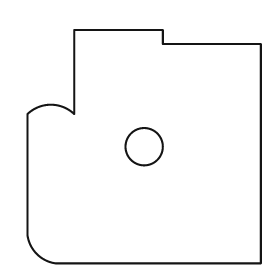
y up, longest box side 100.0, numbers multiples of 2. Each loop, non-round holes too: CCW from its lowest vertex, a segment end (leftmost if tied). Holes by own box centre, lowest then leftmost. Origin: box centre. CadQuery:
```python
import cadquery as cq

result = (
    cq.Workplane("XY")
    .moveTo(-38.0, -50.0)
    .lineTo(50.0, -50.0)
    .lineTo(50.0, 44.0)
    .lineTo(8.0, 44.0)
    .lineTo(8.0, 50.0)
    .lineTo(-30.0, 50.0)
    .lineTo(-30.0, 14.0)
    .threePointArc((-40.0, 18.0), (-50.0, 14.0))
    .lineTo(-50.0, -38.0)
    .threePointArc((-46.0, -46.0), (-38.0, -50.0))
    .close()
    .moveTo(0.0, 0.0)
    .circle(8.0)
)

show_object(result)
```